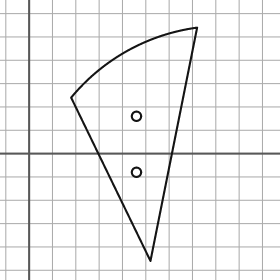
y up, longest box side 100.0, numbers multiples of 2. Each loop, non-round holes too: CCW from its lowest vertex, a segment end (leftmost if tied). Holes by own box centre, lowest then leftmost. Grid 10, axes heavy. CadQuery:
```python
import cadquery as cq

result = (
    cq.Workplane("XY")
    .moveTo(52.0, -46.0)
    .lineTo(72.0, 54.0)
    .threePointArc((42.0, 44.0), (18.0, 24.0))
    .close()
    .moveTo(46.0, -8.0)
    .circle(2.0)
    .moveTo(46.0, 16.0)
    .circle(2.0)
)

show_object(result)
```